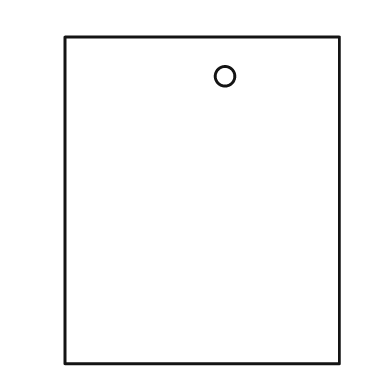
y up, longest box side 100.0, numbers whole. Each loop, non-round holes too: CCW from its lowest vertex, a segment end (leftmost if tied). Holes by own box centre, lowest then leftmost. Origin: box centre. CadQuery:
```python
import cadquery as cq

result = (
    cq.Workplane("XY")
    .moveTo(-42.0, -50.0)
    .lineTo(42.0, -50.0)
    .lineTo(42.0, 50.0)
    .lineTo(-42.0, 50.0)
    .close()
    .moveTo(7.0, 38.0)
    .circle(3.0)
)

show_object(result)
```